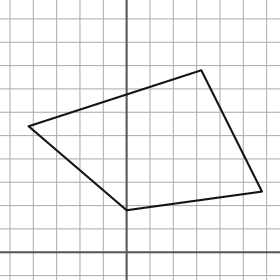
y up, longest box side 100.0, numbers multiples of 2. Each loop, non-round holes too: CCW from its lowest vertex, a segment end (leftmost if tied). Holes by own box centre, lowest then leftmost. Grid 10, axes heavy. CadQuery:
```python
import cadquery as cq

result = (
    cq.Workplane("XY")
    .moveTo(0.0, 18.0)
    .lineTo(58.0, 26.0)
    .lineTo(32.0, 78.0)
    .lineTo(-42.0, 54.0)
    .close()
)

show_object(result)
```